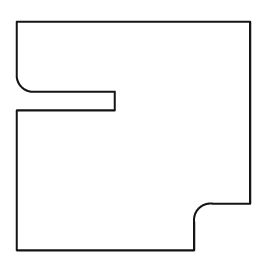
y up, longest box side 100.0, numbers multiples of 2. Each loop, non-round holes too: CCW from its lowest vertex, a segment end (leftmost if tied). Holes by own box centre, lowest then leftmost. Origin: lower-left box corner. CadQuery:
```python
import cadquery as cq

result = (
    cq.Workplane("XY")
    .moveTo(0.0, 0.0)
    .lineTo(76.0, 0.0)
    .lineTo(76.0, 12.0)
    .threePointArc((78.0, 18.0), (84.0, 20.0))
    .lineTo(100.0, 20.0)
    .lineTo(100.0, 98.0)
    .lineTo(0.0, 98.0)
    .lineTo(0.0, 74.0)
    .threePointArc((2.0, 70.0), (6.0, 68.0))
    .lineTo(42.0, 68.0)
    .lineTo(42.0, 60.0)
    .lineTo(0.0, 60.0)
    .close()
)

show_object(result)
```